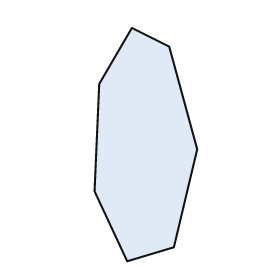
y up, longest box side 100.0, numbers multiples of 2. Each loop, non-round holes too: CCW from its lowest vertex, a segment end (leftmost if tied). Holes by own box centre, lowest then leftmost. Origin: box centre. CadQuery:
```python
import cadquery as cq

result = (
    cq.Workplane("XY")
    .moveTo(-8.0, -50.0)
    .lineTo(12.0, -44.0)
    .lineTo(22.0, -2.0)
    .lineTo(10.0, 42.0)
    .lineTo(-6.0, 50.0)
    .lineTo(-20.0, 26.0)
    .lineTo(-22.0, -20.0)
    .close()
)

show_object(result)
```